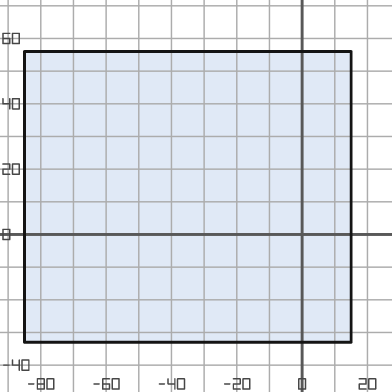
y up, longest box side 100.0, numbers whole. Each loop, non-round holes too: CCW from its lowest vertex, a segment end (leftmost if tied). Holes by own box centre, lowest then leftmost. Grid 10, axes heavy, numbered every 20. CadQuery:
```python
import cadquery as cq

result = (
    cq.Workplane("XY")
    .moveTo(-85.0, -33.0)
    .lineTo(15.0, -33.0)
    .lineTo(15.0, 56.0)
    .lineTo(-85.0, 56.0)
    .close()
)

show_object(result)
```